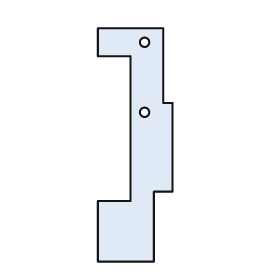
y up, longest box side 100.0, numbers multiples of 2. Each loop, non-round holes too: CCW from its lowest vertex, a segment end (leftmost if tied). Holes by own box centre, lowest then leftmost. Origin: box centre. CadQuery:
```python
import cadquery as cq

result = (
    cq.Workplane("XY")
    .moveTo(-16.0, -50.0)
    .lineTo(8.0, -50.0)
    .lineTo(8.0, -20.0)
    .lineTo(16.0, -20.0)
    .lineTo(16.0, 18.0)
    .lineTo(12.0, 18.0)
    .lineTo(12.0, 50.0)
    .lineTo(-16.0, 50.0)
    .lineTo(-16.0, 38.0)
    .lineTo(-2.0, 38.0)
    .lineTo(-2.0, -24.0)
    .lineTo(-16.0, -24.0)
    .close()
    .moveTo(4.0, 14.0)
    .circle(2.0)
    .moveTo(4.0, 44.0)
    .circle(2.0)
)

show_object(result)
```